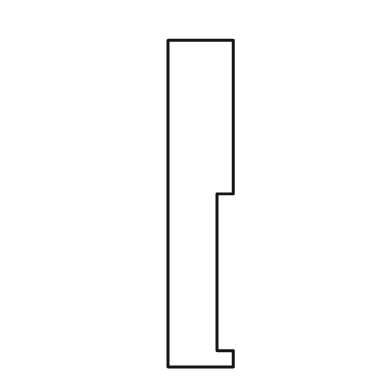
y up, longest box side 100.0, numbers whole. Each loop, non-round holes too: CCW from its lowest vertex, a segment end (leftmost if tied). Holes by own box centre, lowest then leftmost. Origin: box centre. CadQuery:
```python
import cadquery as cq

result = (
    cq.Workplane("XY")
    .moveTo(-10.0, -50.0)
    .lineTo(10.0, -50.0)
    .lineTo(10.0, -45.0)
    .lineTo(5.0, -45.0)
    .lineTo(5.0, 3.0)
    .lineTo(10.0, 3.0)
    .lineTo(10.0, 50.0)
    .lineTo(-10.0, 50.0)
    .close()
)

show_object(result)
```